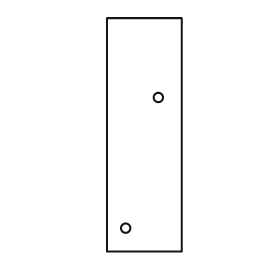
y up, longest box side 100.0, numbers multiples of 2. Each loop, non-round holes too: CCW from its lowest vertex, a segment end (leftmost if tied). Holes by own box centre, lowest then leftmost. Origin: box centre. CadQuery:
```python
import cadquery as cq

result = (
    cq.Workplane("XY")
    .moveTo(-16.0, -50.0)
    .lineTo(16.0, -50.0)
    .lineTo(16.0, 50.0)
    .lineTo(-16.0, 50.0)
    .close()
    .moveTo(-8.0, -40.0)
    .circle(2.0)
    .moveTo(6.0, 16.0)
    .circle(2.0)
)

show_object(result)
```